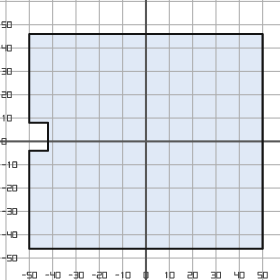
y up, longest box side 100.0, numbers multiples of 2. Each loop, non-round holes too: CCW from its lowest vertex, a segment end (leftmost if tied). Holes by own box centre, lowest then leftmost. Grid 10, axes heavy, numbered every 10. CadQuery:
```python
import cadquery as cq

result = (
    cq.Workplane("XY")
    .moveTo(-50.0, -46.0)
    .lineTo(50.0, -46.0)
    .lineTo(50.0, 46.0)
    .lineTo(-50.0, 46.0)
    .lineTo(-50.0, 8.0)
    .lineTo(-42.0, 8.0)
    .lineTo(-42.0, -4.0)
    .lineTo(-50.0, -4.0)
    .close()
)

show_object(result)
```